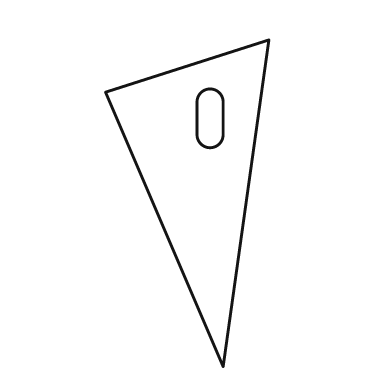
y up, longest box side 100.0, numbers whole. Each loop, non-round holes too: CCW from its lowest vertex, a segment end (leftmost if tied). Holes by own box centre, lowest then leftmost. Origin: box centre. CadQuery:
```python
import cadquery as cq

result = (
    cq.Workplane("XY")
    .moveTo(11.0, -50.0)
    .lineTo(25.0, 50.0)
    .lineTo(-25.0, 34.0)
    .close()
    .moveTo(3.0, 21.0)
    .threePointArc((7.0, 17.0), (11.0, 21.0))
    .lineTo(11.0, 31.0)
    .threePointArc((7.0, 35.0), (3.0, 31.0))
    .close()
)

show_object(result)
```